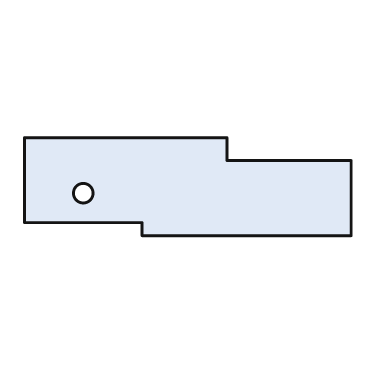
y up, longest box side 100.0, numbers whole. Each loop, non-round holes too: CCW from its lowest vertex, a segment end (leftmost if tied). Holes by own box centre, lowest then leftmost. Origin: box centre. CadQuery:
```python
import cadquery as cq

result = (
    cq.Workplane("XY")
    .moveTo(-14.0, -15.0)
    .lineTo(50.0, -15.0)
    .lineTo(50.0, 8.0)
    .lineTo(12.0, 8.0)
    .lineTo(12.0, 15.0)
    .lineTo(-50.0, 15.0)
    .lineTo(-50.0, -11.0)
    .lineTo(-14.0, -11.0)
    .close()
    .moveTo(-32.0, -2.0)
    .circle(3.0)
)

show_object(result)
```